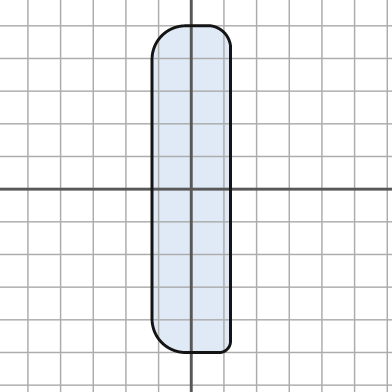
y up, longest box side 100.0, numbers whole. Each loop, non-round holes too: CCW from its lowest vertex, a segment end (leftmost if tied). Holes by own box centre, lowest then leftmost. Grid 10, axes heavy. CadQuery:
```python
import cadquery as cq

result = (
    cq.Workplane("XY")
    .moveTo(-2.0, -50.0)
    .lineTo(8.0, -50.0)
    .threePointArc((11.0, -49.0), (12.0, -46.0))
    .lineTo(12.0, 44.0)
    .threePointArc((10.0, 48.0), (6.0, 50.0))
    .lineTo(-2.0, 50.0)
    .threePointArc((-9.0, 47.0), (-12.0, 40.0))
    .lineTo(-12.0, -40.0)
    .threePointArc((-9.0, -47.0), (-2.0, -50.0))
    .close()
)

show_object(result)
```